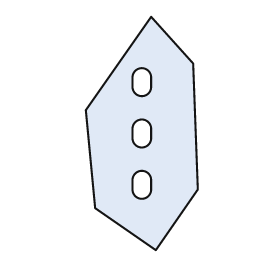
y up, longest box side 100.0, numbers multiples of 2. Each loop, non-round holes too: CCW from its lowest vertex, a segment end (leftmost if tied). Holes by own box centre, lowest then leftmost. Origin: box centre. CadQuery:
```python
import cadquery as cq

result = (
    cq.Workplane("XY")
    .moveTo(6.0, -50.0)
    .lineTo(24.0, -24.0)
    .lineTo(22.0, 30.0)
    .lineTo(4.0, 50.0)
    .lineTo(-24.0, 10.0)
    .lineTo(-20.0, -32.0)
    .close()
    .moveTo(-4.0, -24.0)
    .threePointArc((0.0, -28.0), (4.0, -24.0))
    .lineTo(4.0, -20.0)
    .threePointArc((0.0, -16.0), (-4.0, -20.0))
    .close()
    .moveTo(-4.0, -2.0)
    .threePointArc((0.0, -6.0), (4.0, -2.0))
    .lineTo(4.0, 2.0)
    .threePointArc((0.0, 6.0), (-4.0, 2.0))
    .close()
    .moveTo(-4.0, 20.0)
    .threePointArc((0.0, 16.0), (4.0, 20.0))
    .lineTo(4.0, 24.0)
    .threePointArc((0.0, 28.0), (-4.0, 24.0))
    .close()
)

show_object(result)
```